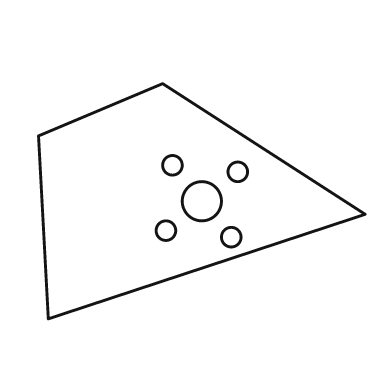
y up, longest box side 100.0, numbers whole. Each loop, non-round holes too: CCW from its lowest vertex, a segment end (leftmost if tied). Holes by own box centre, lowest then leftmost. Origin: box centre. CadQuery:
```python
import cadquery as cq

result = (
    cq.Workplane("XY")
    .moveTo(-47.0, -36.0)
    .lineTo(50.0, -4.0)
    .lineTo(-12.0, 36.0)
    .lineTo(-50.0, 20.0)
    .close()
    .moveTo(9.0, -11.0)
    .circle(3.0)
    .moveTo(-11.0, -9.0)
    .circle(3.0)
    .moveTo(0.0, 0.0)
    .circle(6.0)
    .moveTo(11.0, 9.0)
    .circle(3.0)
    .moveTo(-9.0, 11.0)
    .circle(3.0)
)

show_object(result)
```